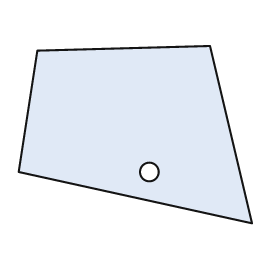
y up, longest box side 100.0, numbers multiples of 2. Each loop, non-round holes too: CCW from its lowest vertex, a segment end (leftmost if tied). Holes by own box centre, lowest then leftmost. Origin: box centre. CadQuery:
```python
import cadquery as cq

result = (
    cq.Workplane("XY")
    .moveTo(50.0, -38.0)
    .lineTo(32.0, 38.0)
    .lineTo(-42.0, 36.0)
    .lineTo(-50.0, -16.0)
    .close()
    .moveTo(6.0, -16.0)
    .circle(4.0)
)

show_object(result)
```